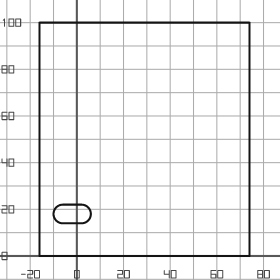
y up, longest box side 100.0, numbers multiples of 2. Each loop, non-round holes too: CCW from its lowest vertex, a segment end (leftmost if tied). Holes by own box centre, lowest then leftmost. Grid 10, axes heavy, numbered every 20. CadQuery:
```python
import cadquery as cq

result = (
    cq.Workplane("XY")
    .moveTo(-16.0, 0.0)
    .lineTo(74.0, 0.0)
    .lineTo(74.0, 100.0)
    .lineTo(-16.0, 100.0)
    .close()
    .moveTo(-6.0, 14.0)
    .lineTo(2.0, 14.0)
    .threePointArc((6.0, 18.0), (2.0, 22.0))
    .lineTo(-6.0, 22.0)
    .threePointArc((-10.0, 18.0), (-6.0, 14.0))
    .close()
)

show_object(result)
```